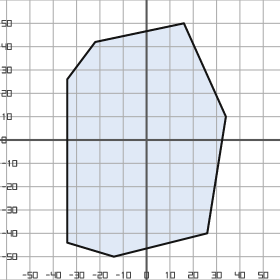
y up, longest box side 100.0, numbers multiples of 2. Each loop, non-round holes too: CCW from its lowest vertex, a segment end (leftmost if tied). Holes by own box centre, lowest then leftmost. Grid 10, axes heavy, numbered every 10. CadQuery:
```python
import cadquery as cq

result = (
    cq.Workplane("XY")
    .moveTo(-14.0, -50.0)
    .lineTo(26.0, -40.0)
    .lineTo(34.0, 10.0)
    .lineTo(16.0, 50.0)
    .lineTo(-22.0, 42.0)
    .lineTo(-34.0, 26.0)
    .lineTo(-34.0, -44.0)
    .close()
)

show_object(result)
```